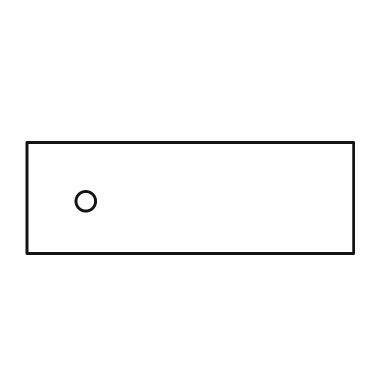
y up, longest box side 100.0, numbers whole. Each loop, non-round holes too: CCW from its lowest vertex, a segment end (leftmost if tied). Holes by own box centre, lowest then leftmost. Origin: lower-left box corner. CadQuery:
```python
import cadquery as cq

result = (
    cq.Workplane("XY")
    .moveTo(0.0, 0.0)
    .lineTo(100.0, 0.0)
    .lineTo(100.0, 34.0)
    .lineTo(0.0, 34.0)
    .close()
    .moveTo(18.0, 16.0)
    .circle(3.0)
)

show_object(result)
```